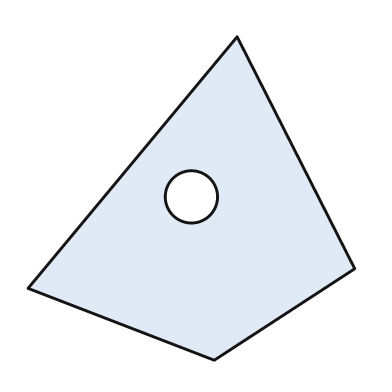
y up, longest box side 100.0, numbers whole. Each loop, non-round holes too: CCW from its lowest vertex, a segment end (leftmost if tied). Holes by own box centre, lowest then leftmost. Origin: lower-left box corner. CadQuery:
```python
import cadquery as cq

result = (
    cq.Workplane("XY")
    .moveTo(57.0, 0.0)
    .lineTo(100.0, 28.0)
    .lineTo(64.0, 99.0)
    .lineTo(0.0, 22.0)
    .close()
    .moveTo(50.0, 50.0)
    .circle(8.0)
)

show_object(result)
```